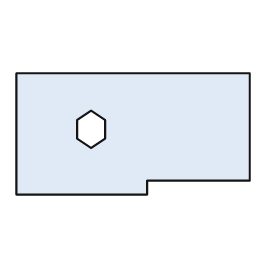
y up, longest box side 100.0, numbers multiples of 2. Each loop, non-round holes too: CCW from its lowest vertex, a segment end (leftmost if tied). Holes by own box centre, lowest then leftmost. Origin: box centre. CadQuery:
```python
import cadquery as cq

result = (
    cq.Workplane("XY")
    .moveTo(-50.0, -26.0)
    .lineTo(6.0, -26.0)
    .lineTo(6.0, -20.0)
    .lineTo(50.0, -20.0)
    .lineTo(50.0, 26.0)
    .lineTo(-50.0, 26.0)
    .close()
    .moveTo(-18.0, -6.0)
    .lineTo(-12.0, -2.0)
    .lineTo(-12.0, 6.0)
    .lineTo(-18.0, 10.0)
    .lineTo(-24.0, 6.0)
    .lineTo(-24.0, -2.0)
    .close()
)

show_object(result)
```